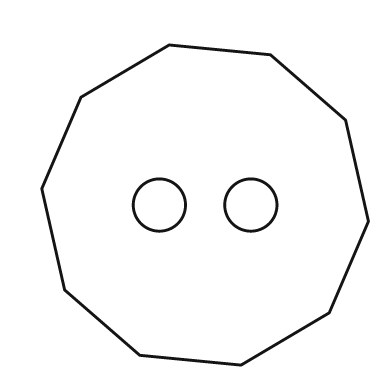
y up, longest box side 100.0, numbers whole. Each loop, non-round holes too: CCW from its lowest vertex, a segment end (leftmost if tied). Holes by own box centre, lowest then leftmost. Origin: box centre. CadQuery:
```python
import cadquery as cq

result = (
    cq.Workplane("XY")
    .moveTo(11.0, -49.0)
    .lineTo(38.0, -33.0)
    .lineTo(50.0, -5.0)
    .lineTo(43.0, 26.0)
    .lineTo(20.0, 46.0)
    .lineTo(-11.0, 49.0)
    .lineTo(-38.0, 33.0)
    .lineTo(-50.0, 5.0)
    .lineTo(-43.0, -26.0)
    .lineTo(-20.0, -46.0)
    .close()
    .moveTo(-14.0, 0.0)
    .circle(8.0)
    .moveTo(14.0, 0.0)
    .circle(8.0)
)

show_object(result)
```